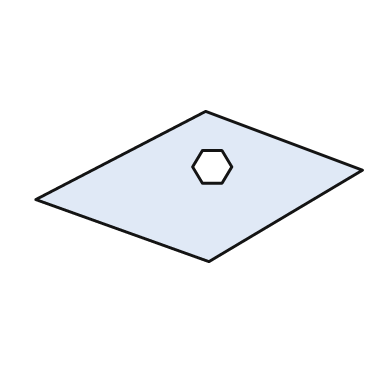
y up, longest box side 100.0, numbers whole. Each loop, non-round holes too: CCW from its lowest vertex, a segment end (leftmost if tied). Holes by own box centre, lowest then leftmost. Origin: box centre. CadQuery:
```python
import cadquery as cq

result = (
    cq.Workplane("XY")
    .moveTo(3.0, -23.0)
    .lineTo(50.0, 5.0)
    .lineTo(2.0, 23.0)
    .lineTo(-50.0, -4.0)
    .close()
    .moveTo(1.0, 1.0)
    .lineTo(7.0, 1.0)
    .lineTo(10.0, 6.0)
    .lineTo(7.0, 11.0)
    .lineTo(1.0, 11.0)
    .lineTo(-2.0, 6.0)
    .close()
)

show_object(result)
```